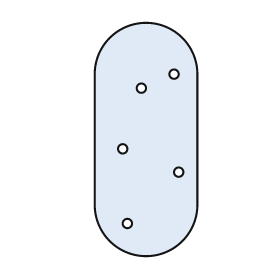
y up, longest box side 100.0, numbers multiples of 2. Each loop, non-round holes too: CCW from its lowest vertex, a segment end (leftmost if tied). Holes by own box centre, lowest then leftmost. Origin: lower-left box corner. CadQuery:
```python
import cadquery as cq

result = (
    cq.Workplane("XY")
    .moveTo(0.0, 22.0)
    .threePointArc((22.0, 0.0), (44.0, 22.0))
    .lineTo(44.0, 78.0)
    .threePointArc((22.0, 100.0), (0.0, 78.0))
    .close()
    .moveTo(14.0, 14.0)
    .circle(2.0)
    .moveTo(36.0, 36.0)
    .circle(2.0)
    .moveTo(12.0, 46.0)
    .circle(2.0)
    .moveTo(20.0, 72.0)
    .circle(2.0)
    .moveTo(34.0, 78.0)
    .circle(2.0)
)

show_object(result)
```